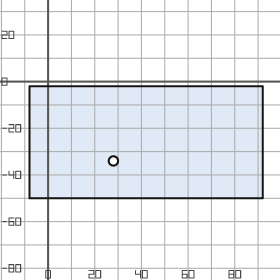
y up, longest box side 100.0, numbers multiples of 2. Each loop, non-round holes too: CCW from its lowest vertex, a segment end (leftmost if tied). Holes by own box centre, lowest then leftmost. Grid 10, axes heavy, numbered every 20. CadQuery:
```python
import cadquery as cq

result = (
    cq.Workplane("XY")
    .moveTo(-8.0, -50.0)
    .lineTo(92.0, -50.0)
    .lineTo(92.0, -2.0)
    .lineTo(-8.0, -2.0)
    .close()
    .moveTo(28.0, -34.0)
    .circle(2.0)
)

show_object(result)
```